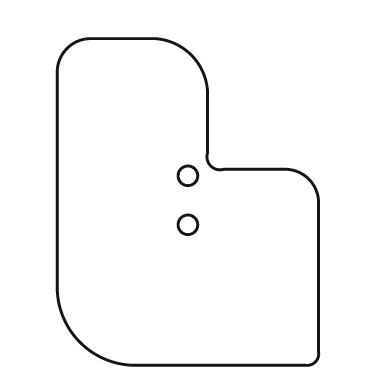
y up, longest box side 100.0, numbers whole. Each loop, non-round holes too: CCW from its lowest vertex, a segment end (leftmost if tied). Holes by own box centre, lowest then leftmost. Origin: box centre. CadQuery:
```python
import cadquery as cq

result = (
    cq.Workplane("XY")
    .moveTo(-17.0, -50.0)
    .lineTo(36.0, -50.0)
    .threePointArc((39.0, -49.0), (40.0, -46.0))
    .lineTo(40.0, 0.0)
    .threePointArc((37.0, 7.0), (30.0, 10.0))
    .lineTo(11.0, 10.0)
    .threePointArc((7.0, 11.0), (6.0, 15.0))
    .lineTo(6.0, 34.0)
    .threePointArc((1.0, 45.0), (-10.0, 50.0))
    .lineTo(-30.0, 50.0)
    .threePointArc((-37.0, 47.0), (-40.0, 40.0))
    .lineTo(-40.0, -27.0)
    .threePointArc((-33.0, -43.0), (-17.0, -50.0))
    .close()
    .moveTo(0.0, -7.0)
    .circle(3.0)
    .moveTo(0.0, 8.0)
    .circle(3.0)
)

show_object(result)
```